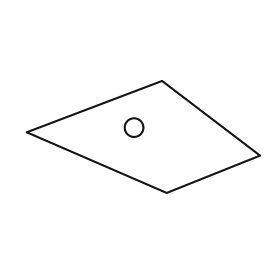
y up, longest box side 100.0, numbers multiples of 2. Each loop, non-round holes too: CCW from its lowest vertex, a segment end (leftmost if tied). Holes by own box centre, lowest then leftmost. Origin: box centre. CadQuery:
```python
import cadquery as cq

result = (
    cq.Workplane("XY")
    .moveTo(10.0, -24.0)
    .lineTo(50.0, -8.0)
    .lineTo(8.0, 24.0)
    .lineTo(-50.0, 2.0)
    .close()
    .moveTo(-4.0, 4.0)
    .circle(4.0)
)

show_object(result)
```